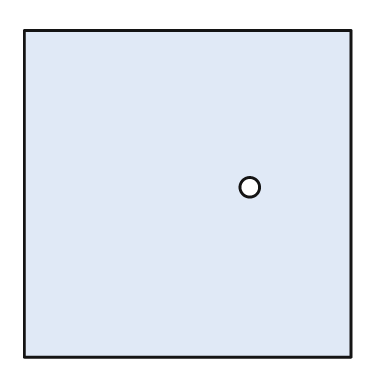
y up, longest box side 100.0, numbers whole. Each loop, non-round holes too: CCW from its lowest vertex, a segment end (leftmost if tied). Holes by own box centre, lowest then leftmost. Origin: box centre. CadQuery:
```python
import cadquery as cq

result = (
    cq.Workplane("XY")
    .moveTo(-50.0, -50.0)
    .lineTo(50.0, -50.0)
    .lineTo(50.0, 50.0)
    .lineTo(-50.0, 50.0)
    .close()
    .moveTo(19.0, 2.0)
    .circle(3.0)
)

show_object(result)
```